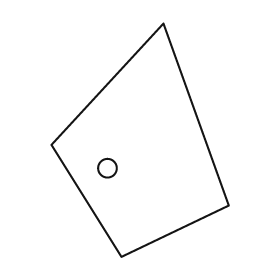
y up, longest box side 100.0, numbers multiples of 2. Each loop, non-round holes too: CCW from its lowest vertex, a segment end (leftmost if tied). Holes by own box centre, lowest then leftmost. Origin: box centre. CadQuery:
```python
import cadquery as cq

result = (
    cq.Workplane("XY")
    .moveTo(-8.0, -50.0)
    .lineTo(38.0, -28.0)
    .lineTo(10.0, 50.0)
    .lineTo(-38.0, -2.0)
    .close()
    .moveTo(-14.0, -12.0)
    .circle(4.0)
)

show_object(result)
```